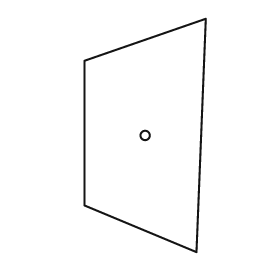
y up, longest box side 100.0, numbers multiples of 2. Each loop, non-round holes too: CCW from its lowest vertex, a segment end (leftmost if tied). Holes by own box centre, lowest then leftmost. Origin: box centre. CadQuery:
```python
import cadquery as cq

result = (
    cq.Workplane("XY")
    .moveTo(22.0, -50.0)
    .lineTo(26.0, 50.0)
    .lineTo(-26.0, 32.0)
    .lineTo(-26.0, -30.0)
    .close()
    .moveTo(0.0, 0.0)
    .circle(2.0)
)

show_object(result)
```